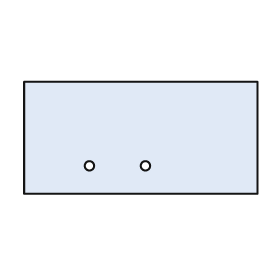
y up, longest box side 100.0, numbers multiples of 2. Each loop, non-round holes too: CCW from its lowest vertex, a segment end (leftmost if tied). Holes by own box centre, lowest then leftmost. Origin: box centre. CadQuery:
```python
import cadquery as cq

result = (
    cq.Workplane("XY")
    .moveTo(-50.0, -24.0)
    .lineTo(50.0, -24.0)
    .lineTo(50.0, 24.0)
    .lineTo(-50.0, 24.0)
    .close()
    .moveTo(-22.0, -12.0)
    .circle(2.0)
    .moveTo(2.0, -12.0)
    .circle(2.0)
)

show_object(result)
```